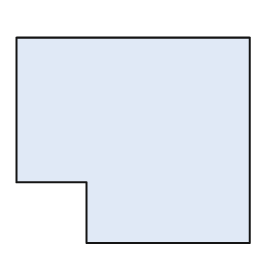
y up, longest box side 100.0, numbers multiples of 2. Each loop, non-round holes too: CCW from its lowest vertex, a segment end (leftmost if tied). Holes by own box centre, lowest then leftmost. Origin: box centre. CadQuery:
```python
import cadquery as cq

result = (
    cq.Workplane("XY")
    .moveTo(-20.0, -44.0)
    .lineTo(50.0, -44.0)
    .lineTo(50.0, 44.0)
    .lineTo(-50.0, 44.0)
    .lineTo(-50.0, -18.0)
    .lineTo(-20.0, -18.0)
    .close()
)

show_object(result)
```